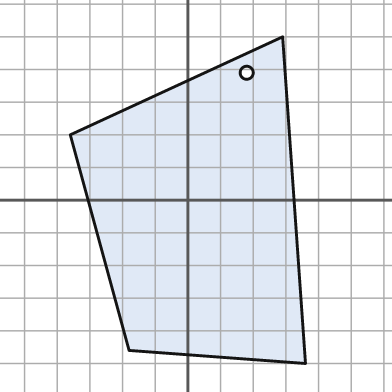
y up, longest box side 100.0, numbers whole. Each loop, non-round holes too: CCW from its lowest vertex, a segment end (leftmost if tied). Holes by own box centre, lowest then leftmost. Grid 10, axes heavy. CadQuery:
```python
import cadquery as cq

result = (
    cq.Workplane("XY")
    .moveTo(36.0, -50.0)
    .lineTo(29.0, 50.0)
    .lineTo(-36.0, 20.0)
    .lineTo(-18.0, -46.0)
    .close()
    .moveTo(18.0, 39.0)
    .circle(2.0)
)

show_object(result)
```